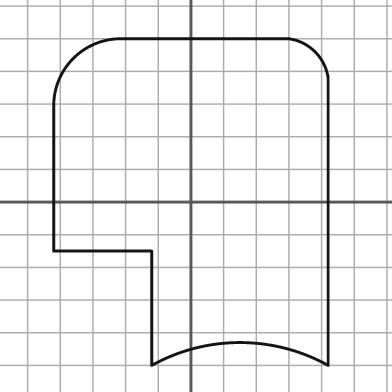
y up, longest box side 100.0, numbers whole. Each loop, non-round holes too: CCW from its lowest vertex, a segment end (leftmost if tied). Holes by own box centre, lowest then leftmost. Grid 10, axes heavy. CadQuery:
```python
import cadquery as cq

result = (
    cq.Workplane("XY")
    .moveTo(-12.0, -50.0)
    .threePointArc((15.0, -43.0), (42.0, -50.0))
    .lineTo(42.0, 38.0)
    .threePointArc((38.0, 46.0), (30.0, 50.0))
    .lineTo(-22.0, 50.0)
    .threePointArc((-36.0, 44.0), (-42.0, 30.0))
    .lineTo(-42.0, -15.0)
    .lineTo(-12.0, -15.0)
    .close()
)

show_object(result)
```